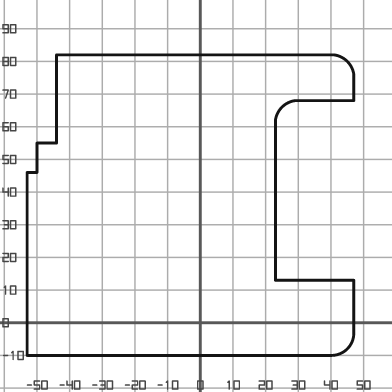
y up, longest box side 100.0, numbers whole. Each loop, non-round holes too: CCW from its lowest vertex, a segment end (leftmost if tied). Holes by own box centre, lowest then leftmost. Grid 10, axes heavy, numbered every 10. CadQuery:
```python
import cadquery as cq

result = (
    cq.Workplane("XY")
    .moveTo(-53.0, -10.0)
    .lineTo(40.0, -10.0)
    .threePointArc((45.0, -8.0), (47.0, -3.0))
    .lineTo(47.0, 13.0)
    .lineTo(23.0, 13.0)
    .lineTo(23.0, 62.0)
    .threePointArc((25.0, 66.0), (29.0, 68.0))
    .lineTo(47.0, 68.0)
    .lineTo(47.0, 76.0)
    .threePointArc((45.0, 80.0), (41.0, 82.0))
    .lineTo(-44.0, 82.0)
    .lineTo(-44.0, 55.0)
    .lineTo(-50.0, 55.0)
    .lineTo(-50.0, 46.0)
    .lineTo(-53.0, 46.0)
    .close()
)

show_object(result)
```